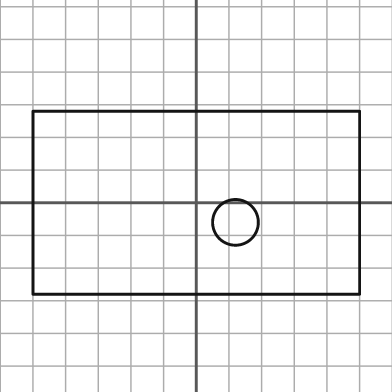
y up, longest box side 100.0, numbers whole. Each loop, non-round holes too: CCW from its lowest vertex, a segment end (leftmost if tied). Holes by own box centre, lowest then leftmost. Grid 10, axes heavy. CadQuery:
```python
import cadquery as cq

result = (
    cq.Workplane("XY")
    .moveTo(-50.0, -28.0)
    .lineTo(50.0, -28.0)
    .lineTo(50.0, 28.0)
    .lineTo(-50.0, 28.0)
    .close()
    .moveTo(12.0, -6.0)
    .circle(7.0)
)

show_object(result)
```